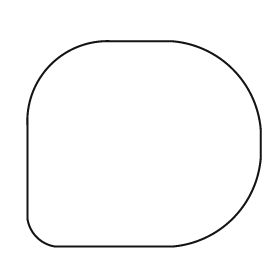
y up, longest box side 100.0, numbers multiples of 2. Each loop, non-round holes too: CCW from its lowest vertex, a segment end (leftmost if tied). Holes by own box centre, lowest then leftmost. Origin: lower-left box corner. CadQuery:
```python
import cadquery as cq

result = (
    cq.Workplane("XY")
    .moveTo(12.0, 0.0)
    .lineTo(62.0, 0.0)
    .threePointArc((88.0, 12.0), (100.0, 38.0))
    .lineTo(100.0, 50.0)
    .threePointArc((88.0, 76.0), (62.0, 88.0))
    .lineTo(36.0, 88.0)
    .threePointArc((10.0, 78.0), (0.0, 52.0))
    .lineTo(0.0, 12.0)
    .threePointArc((4.0, 4.0), (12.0, 0.0))
    .close()
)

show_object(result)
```